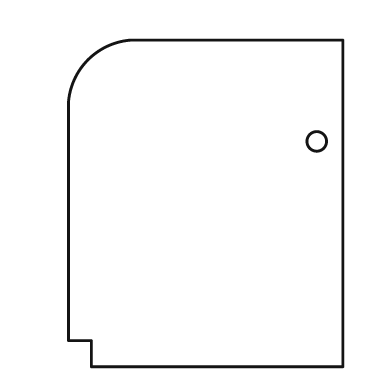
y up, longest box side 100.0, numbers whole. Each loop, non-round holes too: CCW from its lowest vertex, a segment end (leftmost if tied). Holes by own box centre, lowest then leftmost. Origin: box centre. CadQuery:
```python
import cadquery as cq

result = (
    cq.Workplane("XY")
    .moveTo(-35.0, -50.0)
    .lineTo(42.0, -50.0)
    .lineTo(42.0, 50.0)
    .lineTo(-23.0, 50.0)
    .threePointArc((-36.0, 44.0), (-42.0, 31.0))
    .lineTo(-42.0, -42.0)
    .lineTo(-35.0, -42.0)
    .close()
    .moveTo(34.0, 19.0)
    .circle(3.0)
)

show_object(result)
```